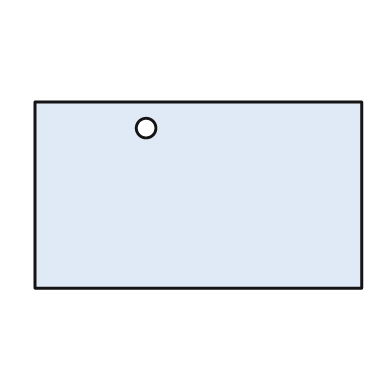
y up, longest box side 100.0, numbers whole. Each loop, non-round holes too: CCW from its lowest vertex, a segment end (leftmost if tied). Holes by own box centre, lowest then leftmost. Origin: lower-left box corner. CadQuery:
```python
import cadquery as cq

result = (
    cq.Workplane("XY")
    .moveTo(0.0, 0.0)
    .lineTo(100.0, 0.0)
    .lineTo(100.0, 57.0)
    .lineTo(0.0, 57.0)
    .close()
    .moveTo(34.0, 49.0)
    .circle(3.0)
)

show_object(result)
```